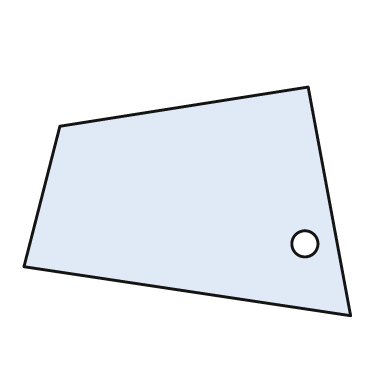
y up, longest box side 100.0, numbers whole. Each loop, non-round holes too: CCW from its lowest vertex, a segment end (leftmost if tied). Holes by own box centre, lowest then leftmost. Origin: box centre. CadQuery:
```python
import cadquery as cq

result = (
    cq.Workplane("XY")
    .moveTo(50.0, -35.0)
    .lineTo(37.0, 35.0)
    .lineTo(-39.0, 23.0)
    .lineTo(-50.0, -20.0)
    .close()
    .moveTo(36.0, -13.0)
    .circle(4.0)
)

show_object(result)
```